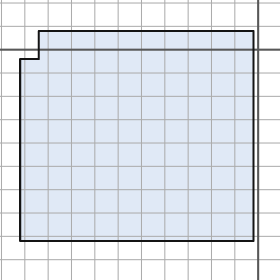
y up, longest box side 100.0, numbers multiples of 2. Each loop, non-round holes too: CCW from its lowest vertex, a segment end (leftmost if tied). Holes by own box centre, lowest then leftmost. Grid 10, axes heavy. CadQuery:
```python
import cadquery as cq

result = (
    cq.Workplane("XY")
    .moveTo(-102.0, -82.0)
    .lineTo(-2.0, -82.0)
    .lineTo(-2.0, 8.0)
    .lineTo(-94.0, 8.0)
    .lineTo(-94.0, -4.0)
    .lineTo(-102.0, -4.0)
    .close()
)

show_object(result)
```